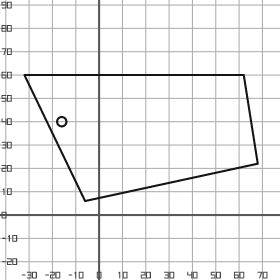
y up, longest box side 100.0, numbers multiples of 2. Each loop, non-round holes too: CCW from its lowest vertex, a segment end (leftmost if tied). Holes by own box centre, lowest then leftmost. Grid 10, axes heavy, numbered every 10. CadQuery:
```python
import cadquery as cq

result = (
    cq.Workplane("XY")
    .moveTo(-6.0, 6.0)
    .lineTo(68.0, 22.0)
    .lineTo(62.0, 60.0)
    .lineTo(-32.0, 60.0)
    .close()
    .moveTo(-16.0, 40.0)
    .circle(2.0)
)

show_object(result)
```